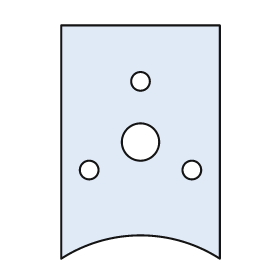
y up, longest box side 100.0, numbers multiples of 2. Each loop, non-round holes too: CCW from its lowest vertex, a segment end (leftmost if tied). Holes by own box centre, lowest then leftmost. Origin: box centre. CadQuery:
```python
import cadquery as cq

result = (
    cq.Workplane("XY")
    .moveTo(-34.0, -50.0)
    .threePointArc((0.0, -40.0), (34.0, -50.0))
    .lineTo(34.0, 50.0)
    .lineTo(-34.0, 50.0)
    .close()
    .moveTo(-22.0, -12.0)
    .circle(4.0)
    .moveTo(22.0, -12.0)
    .circle(4.0)
    .moveTo(0.0, 0.0)
    .circle(8.0)
    .moveTo(0.0, 26.0)
    .circle(4.0)
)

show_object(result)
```